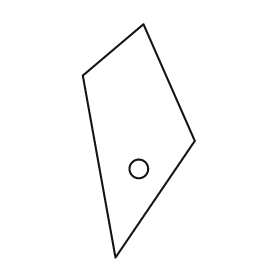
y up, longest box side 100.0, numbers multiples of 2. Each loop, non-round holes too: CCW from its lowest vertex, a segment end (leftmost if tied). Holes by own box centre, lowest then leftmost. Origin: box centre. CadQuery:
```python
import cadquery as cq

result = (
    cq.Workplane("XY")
    .moveTo(-10.0, -50.0)
    .lineTo(24.0, 0.0)
    .lineTo(2.0, 50.0)
    .lineTo(-24.0, 28.0)
    .close()
    .moveTo(0.0, -12.0)
    .circle(4.0)
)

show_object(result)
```